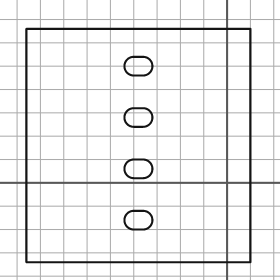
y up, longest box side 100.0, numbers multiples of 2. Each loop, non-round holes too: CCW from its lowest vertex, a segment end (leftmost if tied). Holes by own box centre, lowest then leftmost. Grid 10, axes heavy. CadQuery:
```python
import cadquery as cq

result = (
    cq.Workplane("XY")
    .moveTo(-86.0, -34.0)
    .lineTo(10.0, -34.0)
    .lineTo(10.0, 66.0)
    .lineTo(-86.0, 66.0)
    .close()
    .moveTo(-40.0, -20.0)
    .lineTo(-36.0, -20.0)
    .threePointArc((-32.0, -16.0), (-36.0, -12.0))
    .lineTo(-40.0, -12.0)
    .threePointArc((-44.0, -16.0), (-40.0, -20.0))
    .close()
    .moveTo(-40.0, 2.0)
    .lineTo(-36.0, 2.0)
    .threePointArc((-32.0, 6.0), (-36.0, 10.0))
    .lineTo(-40.0, 10.0)
    .threePointArc((-44.0, 6.0), (-40.0, 2.0))
    .close()
    .moveTo(-40.0, 24.0)
    .lineTo(-36.0, 24.0)
    .threePointArc((-32.0, 28.0), (-36.0, 32.0))
    .lineTo(-40.0, 32.0)
    .threePointArc((-44.0, 28.0), (-40.0, 24.0))
    .close()
    .moveTo(-40.0, 46.0)
    .lineTo(-36.0, 46.0)
    .threePointArc((-32.0, 50.0), (-36.0, 54.0))
    .lineTo(-40.0, 54.0)
    .threePointArc((-44.0, 50.0), (-40.0, 46.0))
    .close()
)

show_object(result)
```